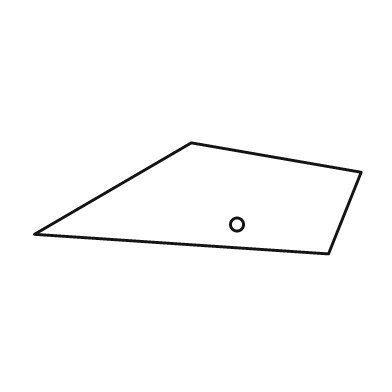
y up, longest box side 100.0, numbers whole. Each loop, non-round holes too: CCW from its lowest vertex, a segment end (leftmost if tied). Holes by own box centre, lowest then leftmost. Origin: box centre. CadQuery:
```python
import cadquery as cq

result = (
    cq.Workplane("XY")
    .moveTo(40.0, -17.0)
    .lineTo(50.0, 8.0)
    .lineTo(-2.0, 17.0)
    .lineTo(-50.0, -11.0)
    .close()
    .moveTo(12.0, -8.0)
    .circle(2.0)
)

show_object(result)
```